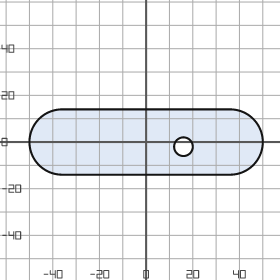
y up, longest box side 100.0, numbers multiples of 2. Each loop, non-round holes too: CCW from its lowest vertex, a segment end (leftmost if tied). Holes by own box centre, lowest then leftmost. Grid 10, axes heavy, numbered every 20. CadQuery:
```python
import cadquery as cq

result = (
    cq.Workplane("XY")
    .moveTo(-36.0, -14.0)
    .lineTo(36.0, -14.0)
    .threePointArc((50.0, 0.0), (36.0, 14.0))
    .lineTo(-36.0, 14.0)
    .threePointArc((-50.0, 0.0), (-36.0, -14.0))
    .close()
    .moveTo(16.0, -2.0)
    .circle(4.0)
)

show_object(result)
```